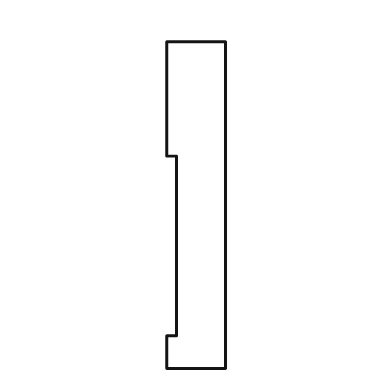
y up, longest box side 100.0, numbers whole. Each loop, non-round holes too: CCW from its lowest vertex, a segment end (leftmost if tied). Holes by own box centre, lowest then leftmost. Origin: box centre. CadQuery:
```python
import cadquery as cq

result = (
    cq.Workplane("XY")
    .moveTo(-9.0, -50.0)
    .lineTo(9.0, -50.0)
    .lineTo(9.0, 50.0)
    .lineTo(-9.0, 50.0)
    .lineTo(-9.0, 15.0)
    .lineTo(-6.0, 15.0)
    .lineTo(-6.0, -40.0)
    .lineTo(-9.0, -40.0)
    .close()
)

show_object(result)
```